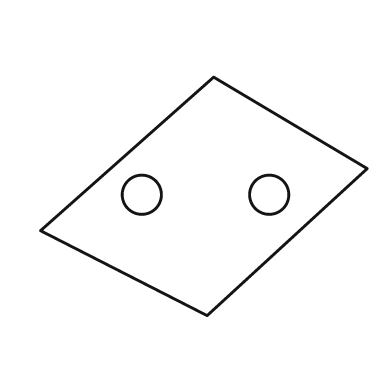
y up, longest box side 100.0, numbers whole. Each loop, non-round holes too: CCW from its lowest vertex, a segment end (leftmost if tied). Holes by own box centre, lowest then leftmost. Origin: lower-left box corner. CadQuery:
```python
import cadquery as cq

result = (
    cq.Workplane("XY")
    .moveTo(51.0, 0.0)
    .lineTo(100.0, 45.0)
    .lineTo(53.0, 73.0)
    .lineTo(0.0, 26.0)
    .close()
    .moveTo(31.0, 37.0)
    .circle(6.0)
    .moveTo(70.0, 37.0)
    .circle(6.0)
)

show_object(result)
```